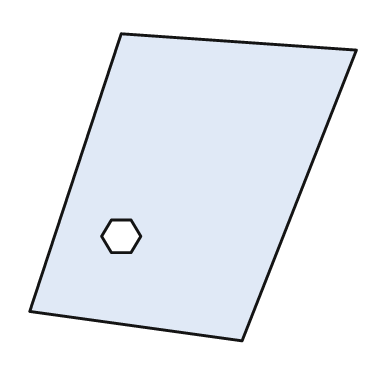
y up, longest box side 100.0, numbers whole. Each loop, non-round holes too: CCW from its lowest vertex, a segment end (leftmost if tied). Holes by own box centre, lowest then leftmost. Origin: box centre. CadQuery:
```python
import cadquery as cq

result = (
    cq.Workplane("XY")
    .moveTo(15.0, -47.0)
    .lineTo(50.0, 42.0)
    .lineTo(-22.0, 47.0)
    .lineTo(-50.0, -38.0)
    .close()
    .moveTo(-25.0, -20.0)
    .lineTo(-19.0, -20.0)
    .lineTo(-16.0, -15.0)
    .lineTo(-19.0, -10.0)
    .lineTo(-25.0, -10.0)
    .lineTo(-28.0, -15.0)
    .close()
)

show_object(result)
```